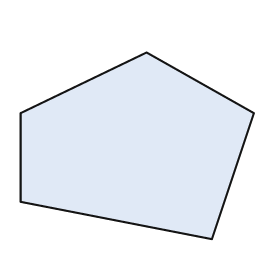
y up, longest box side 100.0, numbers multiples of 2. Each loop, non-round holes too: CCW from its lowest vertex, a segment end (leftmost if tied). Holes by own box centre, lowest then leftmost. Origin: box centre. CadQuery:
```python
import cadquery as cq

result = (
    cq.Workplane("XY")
    .moveTo(32.0, -40.0)
    .lineTo(50.0, 14.0)
    .lineTo(4.0, 40.0)
    .lineTo(-50.0, 14.0)
    .lineTo(-50.0, -24.0)
    .close()
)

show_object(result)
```